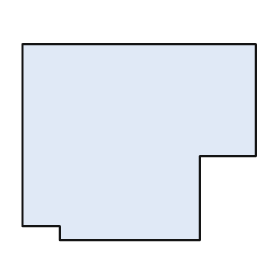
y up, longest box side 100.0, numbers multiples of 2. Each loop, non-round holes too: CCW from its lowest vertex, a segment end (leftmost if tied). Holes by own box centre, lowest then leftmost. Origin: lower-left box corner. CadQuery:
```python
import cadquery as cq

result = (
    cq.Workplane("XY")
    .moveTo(16.0, 0.0)
    .lineTo(76.0, 0.0)
    .lineTo(76.0, 36.0)
    .lineTo(100.0, 36.0)
    .lineTo(100.0, 84.0)
    .lineTo(0.0, 84.0)
    .lineTo(0.0, 6.0)
    .lineTo(16.0, 6.0)
    .close()
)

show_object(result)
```